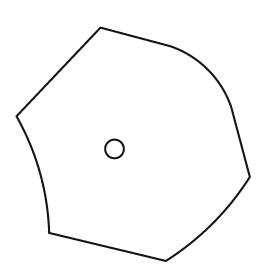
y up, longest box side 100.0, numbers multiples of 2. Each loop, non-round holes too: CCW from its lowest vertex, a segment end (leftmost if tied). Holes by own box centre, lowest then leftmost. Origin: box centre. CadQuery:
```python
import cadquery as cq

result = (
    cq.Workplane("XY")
    .moveTo(14.0, -50.0)
    .threePointArc((34.0, -34.0), (50.0, -14.0))
    .lineTo(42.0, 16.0)
    .threePointArc((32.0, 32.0), (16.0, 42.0))
    .lineTo(-14.0, 50.0)
    .lineTo(-50.0, 12.0)
    .threePointArc((-40.0, -12.0), (-36.0, -38.0))
    .close()
    .moveTo(-8.0, -2.0)
    .circle(4.0)
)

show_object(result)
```